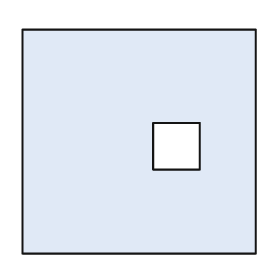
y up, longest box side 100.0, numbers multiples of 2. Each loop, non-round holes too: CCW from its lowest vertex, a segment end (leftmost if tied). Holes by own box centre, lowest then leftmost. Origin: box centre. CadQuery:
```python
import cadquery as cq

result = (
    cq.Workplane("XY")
    .moveTo(-50.0, -48.0)
    .lineTo(50.0, -48.0)
    .lineTo(50.0, 48.0)
    .lineTo(-50.0, 48.0)
    .close()
    .moveTo(6.0, -12.0)
    .lineTo(26.0, -12.0)
    .lineTo(26.0, 8.0)
    .lineTo(6.0, 8.0)
    .close()
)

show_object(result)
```